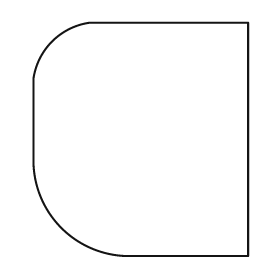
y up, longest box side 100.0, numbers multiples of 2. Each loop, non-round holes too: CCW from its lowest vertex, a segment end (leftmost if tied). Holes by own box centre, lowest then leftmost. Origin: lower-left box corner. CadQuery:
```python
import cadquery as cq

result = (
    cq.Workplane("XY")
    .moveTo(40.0, 0.0)
    .lineTo(92.0, 0.0)
    .lineTo(92.0, 100.0)
    .lineTo(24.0, 100.0)
    .threePointArc((8.0, 92.0), (0.0, 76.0))
    .lineTo(0.0, 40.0)
    .threePointArc((12.0, 12.0), (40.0, 0.0))
    .close()
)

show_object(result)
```